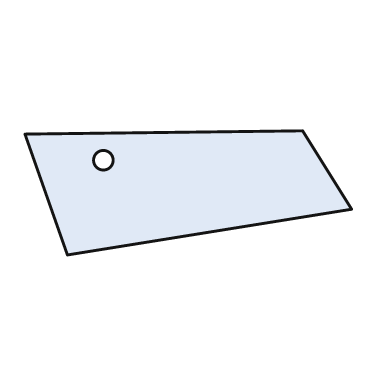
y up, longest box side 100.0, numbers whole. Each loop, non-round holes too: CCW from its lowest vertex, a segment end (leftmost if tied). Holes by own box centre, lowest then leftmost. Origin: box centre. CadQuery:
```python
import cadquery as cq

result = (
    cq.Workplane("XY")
    .moveTo(-37.0, -19.0)
    .lineTo(50.0, -5.0)
    .lineTo(35.0, 19.0)
    .lineTo(-50.0, 18.0)
    .close()
    .moveTo(-26.0, 10.0)
    .circle(3.0)
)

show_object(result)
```